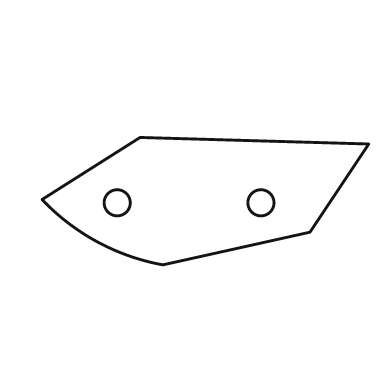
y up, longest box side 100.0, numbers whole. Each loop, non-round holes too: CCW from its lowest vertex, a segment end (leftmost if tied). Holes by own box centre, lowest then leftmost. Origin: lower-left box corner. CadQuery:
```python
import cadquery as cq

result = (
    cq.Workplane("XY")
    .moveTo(37.0, 0.0)
    .lineTo(82.0, 10.0)
    .lineTo(100.0, 37.0)
    .lineTo(30.0, 39.0)
    .lineTo(0.0, 20.0)
    .threePointArc((17.0, 7.0), (37.0, 0.0))
    .close()
    .moveTo(23.0, 19.0)
    .circle(4.0)
    .moveTo(67.0, 19.0)
    .circle(4.0)
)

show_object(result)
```